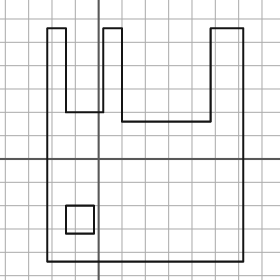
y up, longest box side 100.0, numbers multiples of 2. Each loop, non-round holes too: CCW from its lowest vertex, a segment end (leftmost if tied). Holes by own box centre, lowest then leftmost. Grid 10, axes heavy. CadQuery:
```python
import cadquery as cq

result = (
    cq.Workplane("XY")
    .moveTo(-22.0, -44.0)
    .lineTo(62.0, -44.0)
    .lineTo(62.0, 56.0)
    .lineTo(48.0, 56.0)
    .lineTo(48.0, 16.0)
    .lineTo(10.0, 16.0)
    .lineTo(10.0, 56.0)
    .lineTo(2.0, 56.0)
    .lineTo(2.0, 20.0)
    .lineTo(-14.0, 20.0)
    .lineTo(-14.0, 56.0)
    .lineTo(-22.0, 56.0)
    .close()
    .moveTo(-14.0, -32.0)
    .lineTo(-2.0, -32.0)
    .lineTo(-2.0, -20.0)
    .lineTo(-14.0, -20.0)
    .close()
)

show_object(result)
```